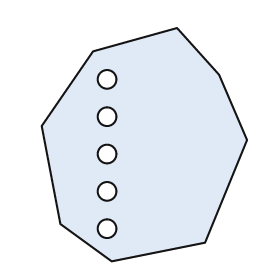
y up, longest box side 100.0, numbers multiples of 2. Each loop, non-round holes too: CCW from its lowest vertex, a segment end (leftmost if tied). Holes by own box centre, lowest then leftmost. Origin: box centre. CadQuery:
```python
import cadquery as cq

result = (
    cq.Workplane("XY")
    .moveTo(-14.0, -50.0)
    .lineTo(26.0, -42.0)
    .lineTo(44.0, 2.0)
    .lineTo(32.0, 30.0)
    .lineTo(14.0, 50.0)
    .lineTo(-22.0, 40.0)
    .lineTo(-44.0, 8.0)
    .lineTo(-36.0, -34.0)
    .close()
    .moveTo(-16.0, -36.0)
    .circle(4.0)
    .moveTo(-16.0, -20.0)
    .circle(4.0)
    .moveTo(-16.0, -4.0)
    .circle(4.0)
    .moveTo(-16.0, 12.0)
    .circle(4.0)
    .moveTo(-16.0, 28.0)
    .circle(4.0)
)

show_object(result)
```